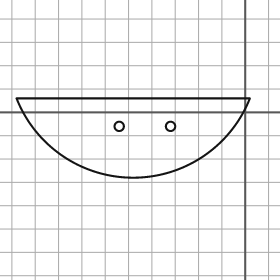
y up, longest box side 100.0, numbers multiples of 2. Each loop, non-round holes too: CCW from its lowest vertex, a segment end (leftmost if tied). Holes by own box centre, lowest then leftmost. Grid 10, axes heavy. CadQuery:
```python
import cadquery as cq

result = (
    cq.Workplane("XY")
    .moveTo(-98.0, 6.0)
    .threePointArc((-48.0, -28.0), (2.0, 6.0))
    .close()
    .moveTo(-54.0, -6.0)
    .circle(2.0)
    .moveTo(-32.0, -6.0)
    .circle(2.0)
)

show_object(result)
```